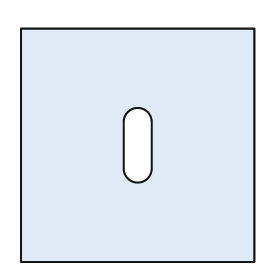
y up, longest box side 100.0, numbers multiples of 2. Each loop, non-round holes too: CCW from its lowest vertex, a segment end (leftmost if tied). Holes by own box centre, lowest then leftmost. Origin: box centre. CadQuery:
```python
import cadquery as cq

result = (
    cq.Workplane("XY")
    .moveTo(-50.0, -50.0)
    .lineTo(50.0, -50.0)
    .lineTo(50.0, 50.0)
    .lineTo(-50.0, 50.0)
    .close()
    .moveTo(-6.0, -10.0)
    .threePointArc((0.0, -16.0), (6.0, -10.0))
    .lineTo(6.0, 10.0)
    .threePointArc((0.0, 16.0), (-6.0, 10.0))
    .close()
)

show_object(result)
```